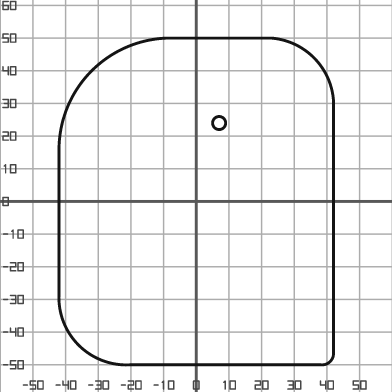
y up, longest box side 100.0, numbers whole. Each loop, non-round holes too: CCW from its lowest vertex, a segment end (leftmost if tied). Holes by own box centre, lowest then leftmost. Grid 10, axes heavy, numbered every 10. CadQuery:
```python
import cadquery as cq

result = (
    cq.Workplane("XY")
    .moveTo(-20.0, -50.0)
    .lineTo(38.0, -50.0)
    .threePointArc((41.0, -49.0), (42.0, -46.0))
    .lineTo(42.0, 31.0)
    .threePointArc((36.0, 44.0), (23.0, 50.0))
    .lineTo(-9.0, 50.0)
    .threePointArc((-32.0, 40.0), (-42.0, 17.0))
    .lineTo(-42.0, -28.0)
    .threePointArc((-36.0, -44.0), (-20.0, -50.0))
    .close()
    .moveTo(7.0, 24.0)
    .circle(2.0)
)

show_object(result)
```